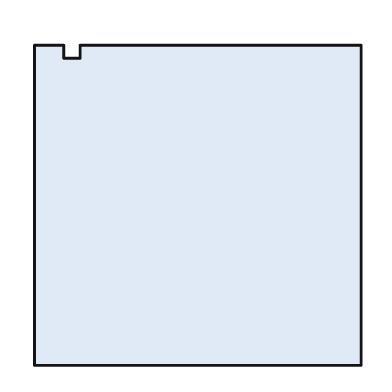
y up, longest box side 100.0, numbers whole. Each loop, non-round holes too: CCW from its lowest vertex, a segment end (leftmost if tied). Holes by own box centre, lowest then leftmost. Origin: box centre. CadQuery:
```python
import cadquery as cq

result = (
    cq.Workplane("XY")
    .moveTo(-50.0, -49.0)
    .lineTo(50.0, -49.0)
    .lineTo(50.0, 49.0)
    .lineTo(-36.0, 49.0)
    .lineTo(-36.0, 45.0)
    .lineTo(-41.0, 45.0)
    .lineTo(-41.0, 49.0)
    .lineTo(-50.0, 49.0)
    .close()
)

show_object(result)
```